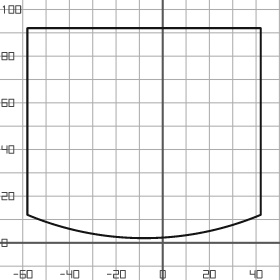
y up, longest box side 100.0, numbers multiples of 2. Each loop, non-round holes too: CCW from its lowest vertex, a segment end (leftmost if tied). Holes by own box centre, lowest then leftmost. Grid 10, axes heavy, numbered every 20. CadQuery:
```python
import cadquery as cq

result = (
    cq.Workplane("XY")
    .moveTo(-58.0, 12.0)
    .threePointArc((-8.0, 2.0), (42.0, 12.0))
    .lineTo(42.0, 92.0)
    .lineTo(-58.0, 92.0)
    .close()
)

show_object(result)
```